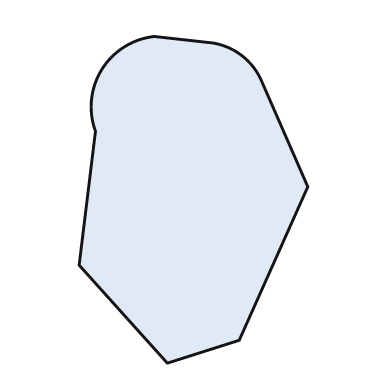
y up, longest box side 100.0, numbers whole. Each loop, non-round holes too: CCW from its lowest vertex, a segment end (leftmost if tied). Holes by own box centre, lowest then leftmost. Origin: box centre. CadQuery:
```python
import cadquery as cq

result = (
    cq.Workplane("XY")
    .moveTo(-8.0, -50.0)
    .lineTo(14.0, -43.0)
    .lineTo(35.0, 4.0)
    .lineTo(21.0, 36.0)
    .threePointArc((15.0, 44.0), (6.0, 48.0))
    .lineTo(-12.0, 50.0)
    .threePointArc((-28.0, 40.0), (-30.0, 21.0))
    .lineTo(-35.0, -20.0)
    .close()
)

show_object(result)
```